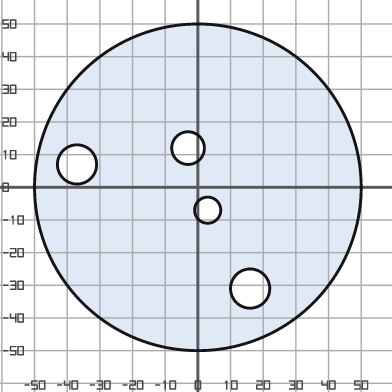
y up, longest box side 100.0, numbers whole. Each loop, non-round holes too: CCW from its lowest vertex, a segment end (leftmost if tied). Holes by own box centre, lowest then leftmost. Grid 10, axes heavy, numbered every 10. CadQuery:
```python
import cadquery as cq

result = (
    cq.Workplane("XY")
    .moveTo(0.0, 0.0)
    .circle(50.0)
    .moveTo(16.0, -31.0)
    .circle(6.0)
    .moveTo(3.0, -7.0)
    .circle(4.0)
    .moveTo(-37.0, 7.0)
    .circle(6.0)
    .moveTo(-3.0, 12.0)
    .circle(5.0)
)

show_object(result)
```